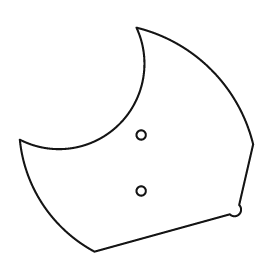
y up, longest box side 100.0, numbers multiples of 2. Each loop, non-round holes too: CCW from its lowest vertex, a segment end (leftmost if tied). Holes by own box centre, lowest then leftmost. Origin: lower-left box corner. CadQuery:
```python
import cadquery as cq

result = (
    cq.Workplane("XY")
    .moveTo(32.0, 0.0)
    .lineTo(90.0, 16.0)
    .threePointArc((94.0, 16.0), (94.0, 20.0))
    .lineTo(100.0, 46.0)
    .threePointArc((82.0, 78.0), (50.0, 96.0))
    .threePointArc((42.0, 54.0), (0.0, 48.0))
    .threePointArc((10.0, 20.0), (32.0, 0.0))
    .close()
    .moveTo(52.0, 26.0)
    .circle(2.0)
    .moveTo(52.0, 50.0)
    .circle(2.0)
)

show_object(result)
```